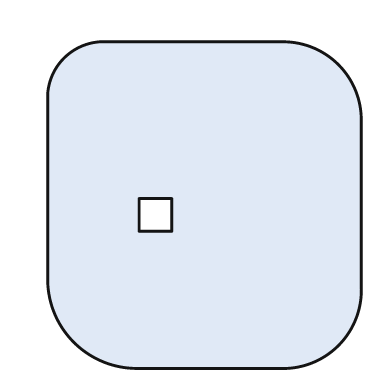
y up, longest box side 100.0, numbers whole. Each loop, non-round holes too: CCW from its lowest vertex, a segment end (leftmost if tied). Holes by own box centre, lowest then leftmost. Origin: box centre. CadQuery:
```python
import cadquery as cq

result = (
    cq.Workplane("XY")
    .moveTo(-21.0, -50.0)
    .lineTo(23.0, -50.0)
    .threePointArc((41.0, -43.0), (48.0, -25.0))
    .lineTo(48.0, 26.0)
    .threePointArc((41.0, 43.0), (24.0, 50.0))
    .lineTo(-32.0, 50.0)
    .threePointArc((-43.0, 45.0), (-48.0, 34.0))
    .lineTo(-48.0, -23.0)
    .threePointArc((-40.0, -42.0), (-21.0, -50.0))
    .close()
    .moveTo(-20.0, -8.0)
    .lineTo(-10.0, -8.0)
    .lineTo(-10.0, 2.0)
    .lineTo(-20.0, 2.0)
    .close()
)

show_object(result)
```